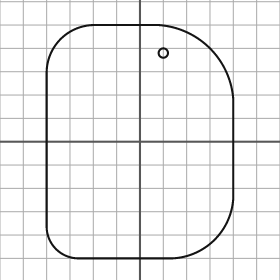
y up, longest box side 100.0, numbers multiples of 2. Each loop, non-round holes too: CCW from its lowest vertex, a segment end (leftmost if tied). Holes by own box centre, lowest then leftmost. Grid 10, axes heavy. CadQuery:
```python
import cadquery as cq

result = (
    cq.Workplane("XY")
    .moveTo(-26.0, -50.0)
    .lineTo(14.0, -50.0)
    .threePointArc((32.0, -42.0), (40.0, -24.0))
    .lineTo(40.0, 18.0)
    .threePointArc((30.0, 40.0), (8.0, 50.0))
    .lineTo(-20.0, 50.0)
    .threePointArc((-34.0, 44.0), (-40.0, 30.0))
    .lineTo(-40.0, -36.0)
    .threePointArc((-36.0, -46.0), (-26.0, -50.0))
    .close()
    .moveTo(10.0, 38.0)
    .circle(2.0)
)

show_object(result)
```